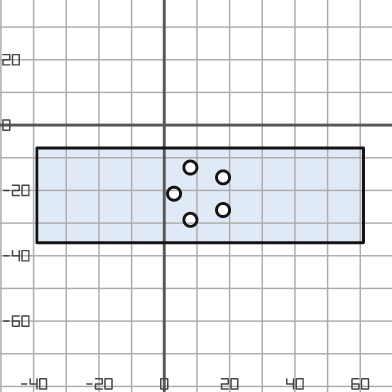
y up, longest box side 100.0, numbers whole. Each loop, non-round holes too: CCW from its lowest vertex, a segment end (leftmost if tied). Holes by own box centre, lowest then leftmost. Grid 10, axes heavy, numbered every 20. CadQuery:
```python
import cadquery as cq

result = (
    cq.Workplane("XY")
    .moveTo(-39.0, -36.0)
    .lineTo(61.0, -36.0)
    .lineTo(61.0, -7.0)
    .lineTo(-39.0, -7.0)
    .close()
    .moveTo(8.0, -29.0)
    .circle(2.0)
    .moveTo(18.0, -26.0)
    .circle(2.0)
    .moveTo(3.0, -21.0)
    .circle(2.0)
    .moveTo(18.0, -16.0)
    .circle(2.0)
    .moveTo(8.0, -13.0)
    .circle(2.0)
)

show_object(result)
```